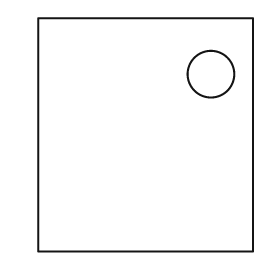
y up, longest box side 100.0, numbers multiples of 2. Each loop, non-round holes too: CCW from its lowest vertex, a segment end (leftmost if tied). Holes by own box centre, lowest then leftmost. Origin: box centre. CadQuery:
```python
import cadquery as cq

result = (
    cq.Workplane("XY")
    .moveTo(-46.0, -50.0)
    .lineTo(46.0, -50.0)
    .lineTo(46.0, 50.0)
    .lineTo(-46.0, 50.0)
    .close()
    .moveTo(28.0, 26.0)
    .circle(10.0)
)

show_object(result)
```